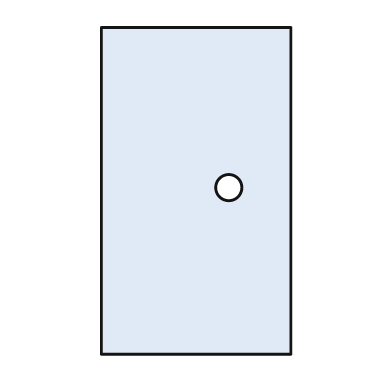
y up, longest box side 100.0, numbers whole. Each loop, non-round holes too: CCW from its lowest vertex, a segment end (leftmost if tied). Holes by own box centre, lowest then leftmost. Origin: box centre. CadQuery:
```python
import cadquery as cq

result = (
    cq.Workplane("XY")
    .moveTo(-29.0, -50.0)
    .lineTo(29.0, -50.0)
    .lineTo(29.0, 50.0)
    .lineTo(-29.0, 50.0)
    .close()
    .moveTo(10.0, 1.0)
    .circle(4.0)
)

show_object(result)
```